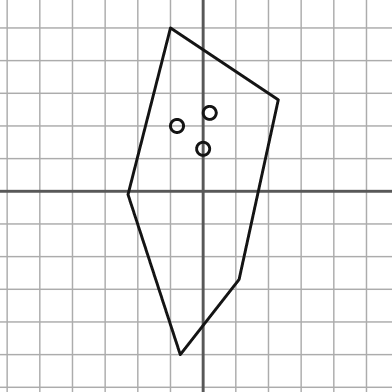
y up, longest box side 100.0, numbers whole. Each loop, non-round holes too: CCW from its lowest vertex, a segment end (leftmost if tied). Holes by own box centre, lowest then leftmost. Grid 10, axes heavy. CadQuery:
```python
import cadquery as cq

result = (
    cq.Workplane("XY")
    .moveTo(-7.0, -50.0)
    .lineTo(11.0, -27.0)
    .lineTo(23.0, 28.0)
    .lineTo(-10.0, 50.0)
    .lineTo(-23.0, -1.0)
    .close()
    .moveTo(0.0, 13.0)
    .circle(2.0)
    .moveTo(-8.0, 20.0)
    .circle(2.0)
    .moveTo(2.0, 24.0)
    .circle(2.0)
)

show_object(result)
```